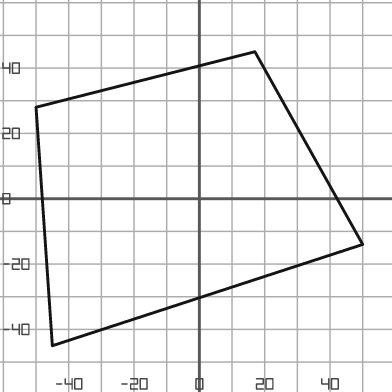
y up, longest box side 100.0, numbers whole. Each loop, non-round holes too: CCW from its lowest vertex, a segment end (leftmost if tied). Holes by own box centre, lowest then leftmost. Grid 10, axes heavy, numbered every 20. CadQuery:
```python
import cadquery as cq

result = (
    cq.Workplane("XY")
    .moveTo(-45.0, -45.0)
    .lineTo(50.0, -14.0)
    .lineTo(17.0, 45.0)
    .lineTo(-50.0, 28.0)
    .close()
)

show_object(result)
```